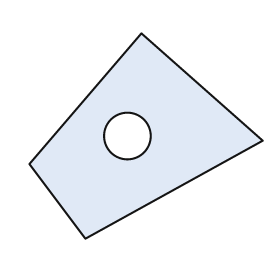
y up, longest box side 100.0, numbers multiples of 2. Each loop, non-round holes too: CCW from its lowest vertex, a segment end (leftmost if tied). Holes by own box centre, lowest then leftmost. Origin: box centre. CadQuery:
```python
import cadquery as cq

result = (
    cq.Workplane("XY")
    .moveTo(-26.0, -44.0)
    .lineTo(50.0, -2.0)
    .lineTo(-2.0, 44.0)
    .lineTo(-50.0, -12.0)
    .close()
    .moveTo(-8.0, 0.0)
    .circle(10.0)
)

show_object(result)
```